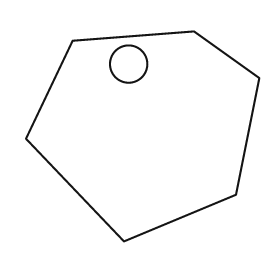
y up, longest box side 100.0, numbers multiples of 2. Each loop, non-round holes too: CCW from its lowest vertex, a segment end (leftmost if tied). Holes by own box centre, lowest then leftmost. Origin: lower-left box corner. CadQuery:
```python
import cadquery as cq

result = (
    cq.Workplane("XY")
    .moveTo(42.0, 0.0)
    .lineTo(90.0, 20.0)
    .lineTo(100.0, 70.0)
    .lineTo(72.0, 90.0)
    .lineTo(20.0, 86.0)
    .lineTo(0.0, 44.0)
    .close()
    .moveTo(44.0, 76.0)
    .circle(8.0)
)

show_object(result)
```